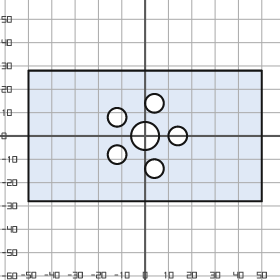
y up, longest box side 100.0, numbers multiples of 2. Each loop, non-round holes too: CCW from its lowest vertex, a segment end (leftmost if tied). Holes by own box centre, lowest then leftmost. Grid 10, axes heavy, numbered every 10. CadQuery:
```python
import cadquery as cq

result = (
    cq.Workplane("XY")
    .moveTo(-50.0, -28.0)
    .lineTo(50.0, -28.0)
    .lineTo(50.0, 28.0)
    .lineTo(-50.0, 28.0)
    .close()
    .moveTo(4.0, -14.0)
    .circle(4.0)
    .moveTo(-12.0, -8.0)
    .circle(4.0)
    .moveTo(0.0, 0.0)
    .circle(6.0)
    .moveTo(14.0, 0.0)
    .circle(4.0)
    .moveTo(-12.0, 8.0)
    .circle(4.0)
    .moveTo(4.0, 14.0)
    .circle(4.0)
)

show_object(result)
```